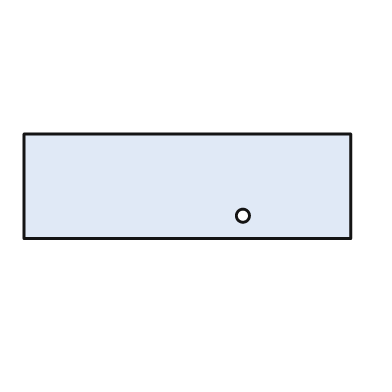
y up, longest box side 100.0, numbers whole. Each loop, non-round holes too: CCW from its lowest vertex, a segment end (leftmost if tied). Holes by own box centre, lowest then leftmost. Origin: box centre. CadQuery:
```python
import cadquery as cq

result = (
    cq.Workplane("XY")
    .moveTo(-50.0, -16.0)
    .lineTo(50.0, -16.0)
    .lineTo(50.0, 16.0)
    .lineTo(-50.0, 16.0)
    .close()
    .moveTo(17.0, -9.0)
    .circle(2.0)
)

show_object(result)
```